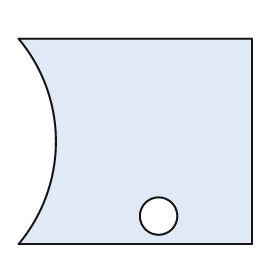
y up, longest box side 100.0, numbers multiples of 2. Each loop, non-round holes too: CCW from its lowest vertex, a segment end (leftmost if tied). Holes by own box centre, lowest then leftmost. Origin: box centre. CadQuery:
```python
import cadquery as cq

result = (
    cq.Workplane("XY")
    .moveTo(-50.0, -44.0)
    .lineTo(50.0, -44.0)
    .lineTo(50.0, 44.0)
    .lineTo(-50.0, 44.0)
    .threePointArc((-34.0, 0.0), (-50.0, -44.0))
    .close()
    .moveTo(10.0, -32.0)
    .circle(8.0)
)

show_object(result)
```